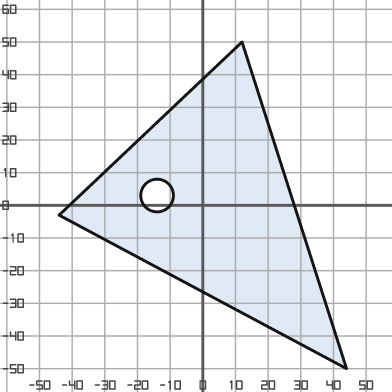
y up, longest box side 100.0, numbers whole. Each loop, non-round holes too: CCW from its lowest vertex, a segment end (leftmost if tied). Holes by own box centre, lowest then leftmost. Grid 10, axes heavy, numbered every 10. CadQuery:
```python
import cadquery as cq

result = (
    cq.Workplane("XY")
    .moveTo(44.0, -50.0)
    .lineTo(12.0, 50.0)
    .lineTo(-44.0, -3.0)
    .close()
    .moveTo(-14.0, 3.0)
    .circle(5.0)
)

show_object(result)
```